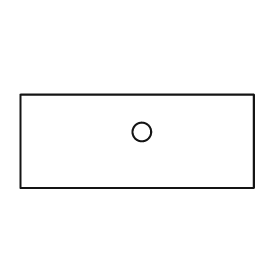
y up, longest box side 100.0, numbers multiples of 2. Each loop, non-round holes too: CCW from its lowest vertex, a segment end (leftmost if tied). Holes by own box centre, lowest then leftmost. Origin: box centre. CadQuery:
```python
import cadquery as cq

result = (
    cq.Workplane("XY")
    .moveTo(-50.0, -20.0)
    .lineTo(50.0, -20.0)
    .lineTo(50.0, 20.0)
    .lineTo(-50.0, 20.0)
    .close()
    .moveTo(2.0, 4.0)
    .circle(4.0)
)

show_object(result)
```